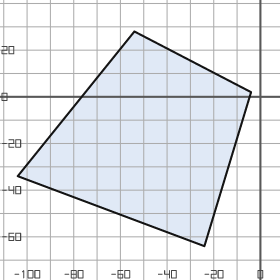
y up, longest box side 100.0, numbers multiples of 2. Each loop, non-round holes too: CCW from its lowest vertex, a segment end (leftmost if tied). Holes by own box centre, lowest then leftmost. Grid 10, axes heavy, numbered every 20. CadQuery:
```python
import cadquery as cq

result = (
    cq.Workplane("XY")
    .moveTo(-24.0, -64.0)
    .lineTo(-4.0, 2.0)
    .lineTo(-54.0, 28.0)
    .lineTo(-104.0, -34.0)
    .close()
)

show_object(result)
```